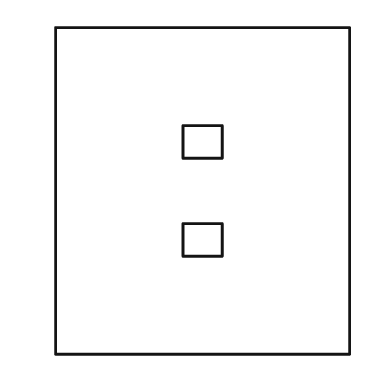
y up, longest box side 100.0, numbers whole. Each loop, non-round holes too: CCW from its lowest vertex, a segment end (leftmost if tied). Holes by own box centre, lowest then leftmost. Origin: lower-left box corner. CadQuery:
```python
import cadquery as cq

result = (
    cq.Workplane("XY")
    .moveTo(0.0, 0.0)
    .lineTo(90.0, 0.0)
    .lineTo(90.0, 100.0)
    .lineTo(0.0, 100.0)
    .close()
    .moveTo(39.0, 30.0)
    .lineTo(51.0, 30.0)
    .lineTo(51.0, 40.0)
    .lineTo(39.0, 40.0)
    .close()
    .moveTo(39.0, 60.0)
    .lineTo(51.0, 60.0)
    .lineTo(51.0, 70.0)
    .lineTo(39.0, 70.0)
    .close()
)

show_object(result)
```